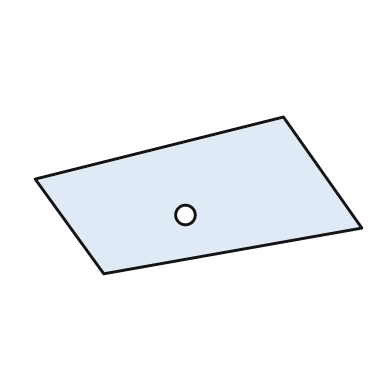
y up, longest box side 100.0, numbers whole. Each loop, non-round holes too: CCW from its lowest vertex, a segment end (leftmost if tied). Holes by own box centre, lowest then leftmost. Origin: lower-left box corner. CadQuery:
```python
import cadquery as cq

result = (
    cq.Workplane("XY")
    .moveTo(21.0, 0.0)
    .lineTo(100.0, 14.0)
    .lineTo(76.0, 48.0)
    .lineTo(0.0, 29.0)
    .close()
    .moveTo(46.0, 18.0)
    .circle(3.0)
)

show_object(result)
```